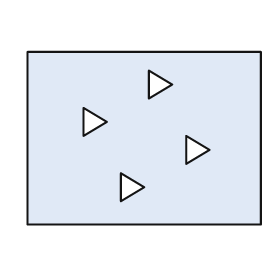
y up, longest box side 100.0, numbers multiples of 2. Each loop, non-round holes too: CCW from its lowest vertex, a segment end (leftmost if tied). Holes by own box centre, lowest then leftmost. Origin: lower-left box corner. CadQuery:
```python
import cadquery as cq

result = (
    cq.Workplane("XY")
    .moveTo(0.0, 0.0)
    .lineTo(100.0, 0.0)
    .lineTo(100.0, 74.0)
    .lineTo(0.0, 74.0)
    .close()
    .moveTo(40.0, 10.0)
    .lineTo(50.0, 16.0)
    .lineTo(40.0, 22.0)
    .close()
    .moveTo(68.0, 26.0)
    .lineTo(78.0, 32.0)
    .lineTo(68.0, 38.0)
    .close()
    .moveTo(24.0, 38.0)
    .lineTo(34.0, 44.0)
    .lineTo(24.0, 50.0)
    .close()
    .moveTo(52.0, 54.0)
    .lineTo(62.0, 60.0)
    .lineTo(52.0, 66.0)
    .close()
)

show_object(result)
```